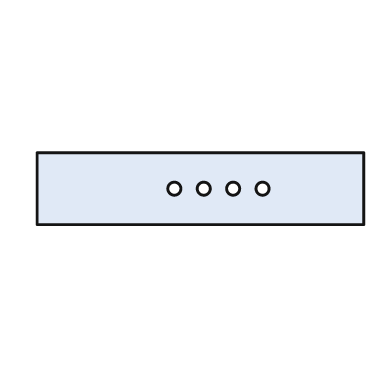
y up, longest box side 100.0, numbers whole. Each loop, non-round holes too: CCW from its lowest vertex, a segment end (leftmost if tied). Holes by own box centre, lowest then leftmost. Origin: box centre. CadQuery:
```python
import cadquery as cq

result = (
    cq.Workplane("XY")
    .moveTo(-50.0, -11.0)
    .lineTo(50.0, -11.0)
    .lineTo(50.0, 11.0)
    .lineTo(-50.0, 11.0)
    .close()
    .moveTo(-8.0, 0.0)
    .circle(2.0)
    .moveTo(1.0, 0.0)
    .circle(2.0)
    .moveTo(10.0, 0.0)
    .circle(2.0)
    .moveTo(19.0, 0.0)
    .circle(2.0)
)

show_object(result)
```